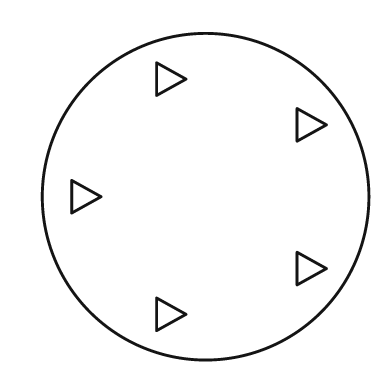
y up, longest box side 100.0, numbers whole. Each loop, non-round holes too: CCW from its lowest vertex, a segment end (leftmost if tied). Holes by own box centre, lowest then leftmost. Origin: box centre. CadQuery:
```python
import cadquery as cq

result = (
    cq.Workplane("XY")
    .moveTo(0.0, 0.0)
    .circle(50.0)
    .moveTo(-15.0, -41.0)
    .lineTo(-6.0, -36.0)
    .lineTo(-15.0, -31.0)
    .close()
    .moveTo(28.0, -27.0)
    .lineTo(37.0, -22.0)
    .lineTo(28.0, -17.0)
    .close()
    .moveTo(-41.0, -5.0)
    .lineTo(-32.0, 0.0)
    .lineTo(-41.0, 5.0)
    .close()
    .moveTo(28.0, 17.0)
    .lineTo(37.0, 22.0)
    .lineTo(28.0, 27.0)
    .close()
    .moveTo(-15.0, 31.0)
    .lineTo(-6.0, 36.0)
    .lineTo(-15.0, 41.0)
    .close()
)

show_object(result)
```